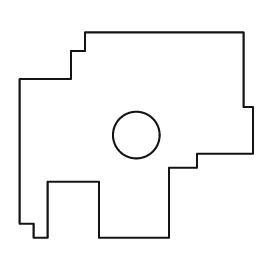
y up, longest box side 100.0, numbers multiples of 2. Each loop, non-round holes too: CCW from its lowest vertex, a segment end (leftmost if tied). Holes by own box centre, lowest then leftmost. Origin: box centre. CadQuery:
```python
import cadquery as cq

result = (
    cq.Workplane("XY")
    .moveTo(-44.0, -44.0)
    .lineTo(-38.0, -44.0)
    .lineTo(-38.0, -20.0)
    .lineTo(-16.0, -20.0)
    .lineTo(-16.0, -44.0)
    .lineTo(14.0, -44.0)
    .lineTo(14.0, -14.0)
    .lineTo(26.0, -14.0)
    .lineTo(26.0, -8.0)
    .lineTo(50.0, -8.0)
    .lineTo(50.0, 12.0)
    .lineTo(46.0, 12.0)
    .lineTo(46.0, 44.0)
    .lineTo(-22.0, 44.0)
    .lineTo(-22.0, 36.0)
    .lineTo(-28.0, 36.0)
    .lineTo(-28.0, 24.0)
    .lineTo(-50.0, 24.0)
    .lineTo(-50.0, -38.0)
    .lineTo(-44.0, -38.0)
    .close()
    .moveTo(0.0, 0.0)
    .circle(10.0)
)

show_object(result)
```